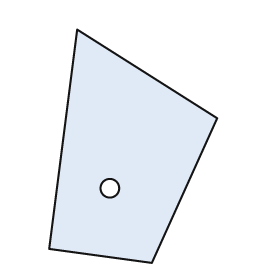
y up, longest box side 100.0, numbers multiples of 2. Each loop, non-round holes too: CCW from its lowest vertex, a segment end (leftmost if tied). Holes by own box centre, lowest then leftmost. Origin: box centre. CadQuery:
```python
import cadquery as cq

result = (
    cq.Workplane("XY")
    .moveTo(8.0, -50.0)
    .lineTo(36.0, 12.0)
    .lineTo(-24.0, 50.0)
    .lineTo(-36.0, -44.0)
    .close()
    .moveTo(-10.0, -18.0)
    .circle(4.0)
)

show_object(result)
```